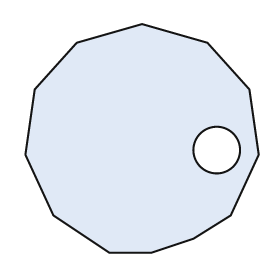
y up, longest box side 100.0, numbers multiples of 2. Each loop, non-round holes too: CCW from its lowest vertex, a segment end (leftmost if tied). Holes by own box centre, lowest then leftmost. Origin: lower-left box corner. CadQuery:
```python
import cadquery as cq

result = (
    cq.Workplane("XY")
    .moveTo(36.0, 0.0)
    .lineTo(54.0, 0.0)
    .lineTo(72.0, 6.0)
    .lineTo(88.0, 16.0)
    .lineTo(100.0, 42.0)
    .lineTo(96.0, 70.0)
    .lineTo(78.0, 90.0)
    .lineTo(50.0, 98.0)
    .lineTo(22.0, 90.0)
    .lineTo(4.0, 70.0)
    .lineTo(0.0, 42.0)
    .lineTo(12.0, 16.0)
    .close()
    .moveTo(82.0, 44.0)
    .circle(10.0)
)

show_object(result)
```